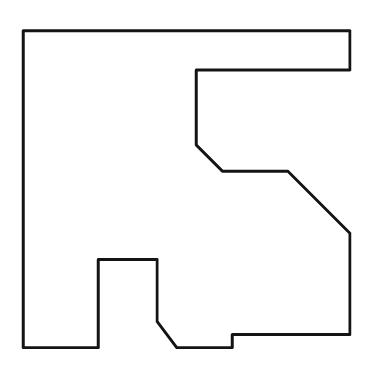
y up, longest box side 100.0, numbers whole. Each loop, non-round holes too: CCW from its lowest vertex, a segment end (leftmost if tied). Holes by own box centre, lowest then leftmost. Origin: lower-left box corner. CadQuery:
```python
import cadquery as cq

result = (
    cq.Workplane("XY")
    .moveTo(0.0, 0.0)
    .lineTo(23.0, 0.0)
    .lineTo(23.0, 27.0)
    .lineTo(41.0, 27.0)
    .lineTo(41.0, 8.0)
    .lineTo(47.0, 0.0)
    .lineTo(64.0, 0.0)
    .lineTo(64.0, 4.0)
    .lineTo(100.0, 4.0)
    .lineTo(100.0, 35.0)
    .lineTo(81.0, 54.0)
    .lineTo(61.0, 54.0)
    .lineTo(53.0, 62.0)
    .lineTo(53.0, 85.0)
    .lineTo(100.0, 85.0)
    .lineTo(100.0, 97.0)
    .lineTo(0.0, 97.0)
    .close()
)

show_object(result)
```